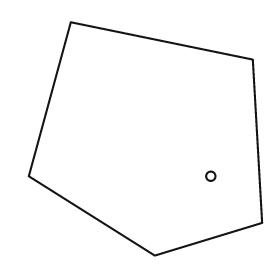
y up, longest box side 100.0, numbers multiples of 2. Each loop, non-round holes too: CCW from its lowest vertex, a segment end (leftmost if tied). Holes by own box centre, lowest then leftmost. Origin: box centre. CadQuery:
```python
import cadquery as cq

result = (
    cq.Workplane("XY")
    .moveTo(4.0, -50.0)
    .lineTo(50.0, -36.0)
    .lineTo(46.0, 34.0)
    .lineTo(-32.0, 50.0)
    .lineTo(-50.0, -16.0)
    .close()
    .moveTo(28.0, -16.0)
    .circle(2.0)
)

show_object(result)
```